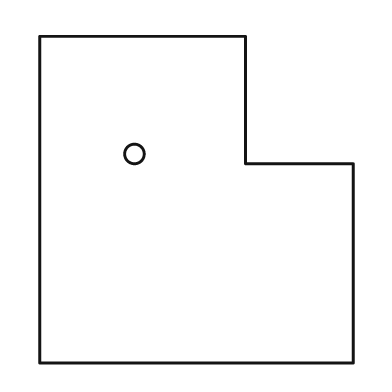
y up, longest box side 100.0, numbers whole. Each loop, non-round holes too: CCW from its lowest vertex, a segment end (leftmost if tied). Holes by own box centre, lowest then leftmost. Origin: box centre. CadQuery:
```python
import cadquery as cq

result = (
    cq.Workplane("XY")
    .moveTo(-48.0, -50.0)
    .lineTo(48.0, -50.0)
    .lineTo(48.0, 11.0)
    .lineTo(15.0, 11.0)
    .lineTo(15.0, 50.0)
    .lineTo(-48.0, 50.0)
    .close()
    .moveTo(-19.0, 14.0)
    .circle(3.0)
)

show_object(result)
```